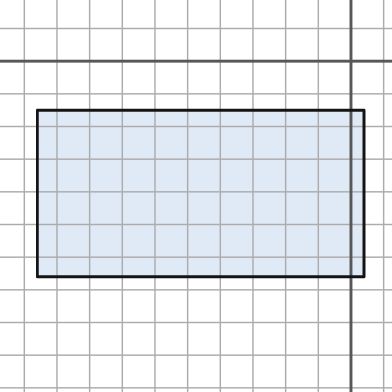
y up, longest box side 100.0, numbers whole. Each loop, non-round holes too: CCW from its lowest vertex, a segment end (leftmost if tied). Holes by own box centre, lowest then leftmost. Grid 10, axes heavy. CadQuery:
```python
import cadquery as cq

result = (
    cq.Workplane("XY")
    .moveTo(-96.0, -66.0)
    .lineTo(4.0, -66.0)
    .lineTo(4.0, -15.0)
    .lineTo(-96.0, -15.0)
    .close()
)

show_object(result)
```